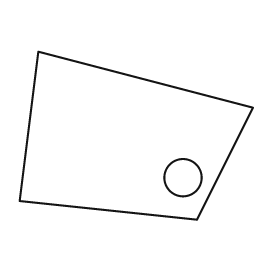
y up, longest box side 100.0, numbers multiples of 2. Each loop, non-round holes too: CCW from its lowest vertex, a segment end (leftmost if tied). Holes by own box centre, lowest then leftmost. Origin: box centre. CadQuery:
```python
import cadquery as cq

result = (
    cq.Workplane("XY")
    .moveTo(26.0, -36.0)
    .lineTo(50.0, 12.0)
    .lineTo(-42.0, 36.0)
    .lineTo(-50.0, -28.0)
    .close()
    .moveTo(20.0, -18.0)
    .circle(8.0)
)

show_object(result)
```